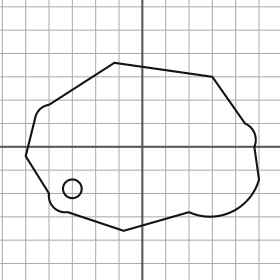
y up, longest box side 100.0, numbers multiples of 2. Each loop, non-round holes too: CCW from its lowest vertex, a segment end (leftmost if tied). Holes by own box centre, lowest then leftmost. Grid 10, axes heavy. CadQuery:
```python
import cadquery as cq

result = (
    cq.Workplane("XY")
    .moveTo(-8.0, -36.0)
    .lineTo(20.0, -28.0)
    .threePointArc((38.0, -28.0), (50.0, -14.0))
    .lineTo(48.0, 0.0)
    .threePointArc((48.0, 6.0), (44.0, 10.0))
    .lineTo(30.0, 30.0)
    .lineTo(-12.0, 36.0)
    .lineTo(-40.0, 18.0)
    .threePointArc((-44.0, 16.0), (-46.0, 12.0))
    .lineTo(-50.0, -4.0)
    .lineTo(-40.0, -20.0)
    .threePointArc((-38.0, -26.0), (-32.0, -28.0))
    .close()
    .moveTo(-30.0, -18.0)
    .circle(4.0)
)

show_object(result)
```